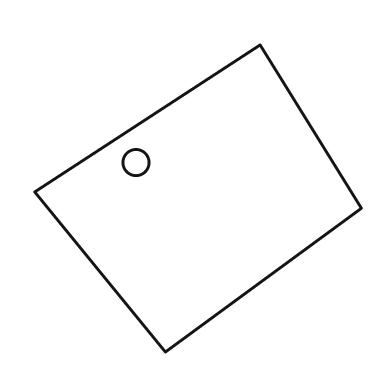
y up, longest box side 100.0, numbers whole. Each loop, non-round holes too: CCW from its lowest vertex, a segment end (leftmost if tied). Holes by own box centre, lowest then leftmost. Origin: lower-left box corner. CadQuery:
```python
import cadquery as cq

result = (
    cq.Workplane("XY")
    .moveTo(40.0, 0.0)
    .lineTo(100.0, 44.0)
    .lineTo(69.0, 94.0)
    .lineTo(0.0, 49.0)
    .close()
    .moveTo(31.0, 58.0)
    .circle(4.0)
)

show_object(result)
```